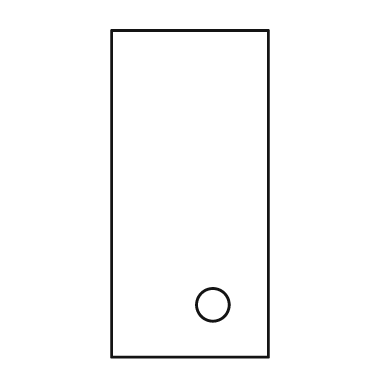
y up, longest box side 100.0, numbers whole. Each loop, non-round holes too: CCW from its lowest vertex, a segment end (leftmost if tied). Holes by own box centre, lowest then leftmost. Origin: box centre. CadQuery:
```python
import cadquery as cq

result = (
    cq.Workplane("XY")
    .moveTo(-24.0, -50.0)
    .lineTo(24.0, -50.0)
    .lineTo(24.0, 50.0)
    .lineTo(-24.0, 50.0)
    .close()
    .moveTo(7.0, -34.0)
    .circle(5.0)
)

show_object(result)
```